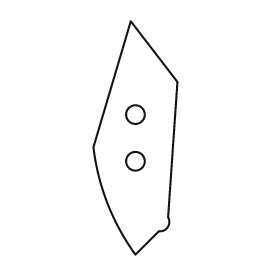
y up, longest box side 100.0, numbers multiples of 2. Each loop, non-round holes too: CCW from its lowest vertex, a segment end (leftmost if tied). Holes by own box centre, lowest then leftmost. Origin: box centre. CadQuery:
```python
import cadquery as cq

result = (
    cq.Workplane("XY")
    .moveTo(0.0, -50.0)
    .lineTo(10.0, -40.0)
    .threePointArc((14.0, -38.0), (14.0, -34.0))
    .lineTo(18.0, 24.0)
    .lineTo(-2.0, 50.0)
    .lineTo(-18.0, -4.0)
    .threePointArc((-12.0, -28.0), (0.0, -50.0))
    .close()
    .moveTo(0.0, -10.0)
    .circle(4.0)
    .moveTo(0.0, 10.0)
    .circle(4.0)
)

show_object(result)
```